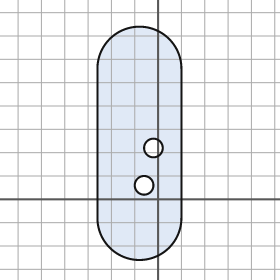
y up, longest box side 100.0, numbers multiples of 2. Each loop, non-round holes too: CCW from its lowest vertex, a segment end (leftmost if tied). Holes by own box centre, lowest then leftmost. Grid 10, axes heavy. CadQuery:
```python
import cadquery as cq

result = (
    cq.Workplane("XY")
    .moveTo(-26.0, -8.0)
    .threePointArc((-8.0, -26.0), (10.0, -8.0))
    .lineTo(10.0, 56.0)
    .threePointArc((-8.0, 74.0), (-26.0, 56.0))
    .close()
    .moveTo(-6.0, 6.0)
    .circle(4.0)
    .moveTo(-2.0, 22.0)
    .circle(4.0)
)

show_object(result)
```